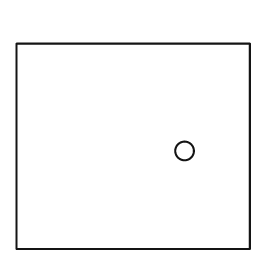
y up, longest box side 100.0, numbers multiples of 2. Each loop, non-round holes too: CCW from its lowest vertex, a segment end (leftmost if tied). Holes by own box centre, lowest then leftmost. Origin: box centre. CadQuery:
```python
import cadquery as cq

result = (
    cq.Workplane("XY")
    .moveTo(-50.0, -44.0)
    .lineTo(50.0, -44.0)
    .lineTo(50.0, 44.0)
    .lineTo(-50.0, 44.0)
    .close()
    .moveTo(22.0, -2.0)
    .circle(4.0)
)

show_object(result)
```